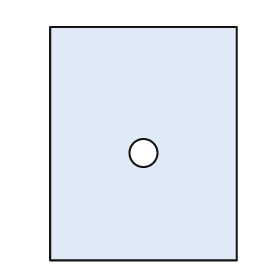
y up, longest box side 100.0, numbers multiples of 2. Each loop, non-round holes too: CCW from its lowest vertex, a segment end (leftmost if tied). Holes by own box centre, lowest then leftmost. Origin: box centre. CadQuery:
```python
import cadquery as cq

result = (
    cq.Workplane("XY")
    .moveTo(-40.0, -50.0)
    .lineTo(40.0, -50.0)
    .lineTo(40.0, 50.0)
    .lineTo(-40.0, 50.0)
    .close()
    .moveTo(0.0, -4.0)
    .circle(6.0)
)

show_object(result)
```